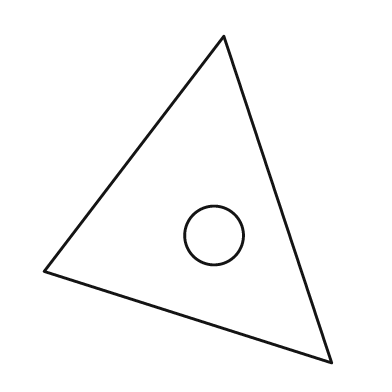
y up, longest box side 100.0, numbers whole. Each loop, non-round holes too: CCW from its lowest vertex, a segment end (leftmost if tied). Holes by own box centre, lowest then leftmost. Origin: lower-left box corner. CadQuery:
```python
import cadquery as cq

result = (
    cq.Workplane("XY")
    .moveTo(88.0, 0.0)
    .lineTo(55.0, 100.0)
    .lineTo(0.0, 28.0)
    .close()
    .moveTo(52.0, 39.0)
    .circle(9.0)
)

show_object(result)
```